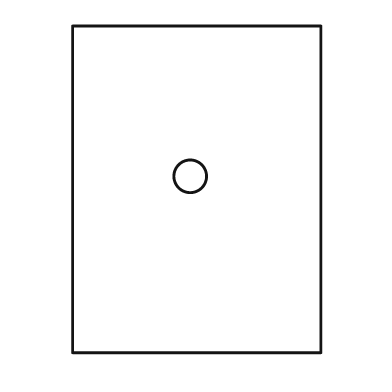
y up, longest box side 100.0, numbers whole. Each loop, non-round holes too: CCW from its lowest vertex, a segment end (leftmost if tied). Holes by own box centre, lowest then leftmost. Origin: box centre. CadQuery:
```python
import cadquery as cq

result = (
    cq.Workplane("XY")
    .moveTo(-38.0, -50.0)
    .lineTo(38.0, -50.0)
    .lineTo(38.0, 50.0)
    .lineTo(-38.0, 50.0)
    .close()
    .moveTo(-2.0, 4.0)
    .circle(5.0)
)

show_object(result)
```